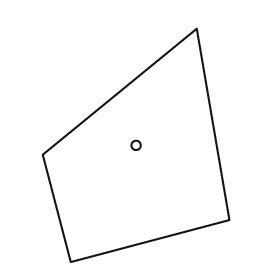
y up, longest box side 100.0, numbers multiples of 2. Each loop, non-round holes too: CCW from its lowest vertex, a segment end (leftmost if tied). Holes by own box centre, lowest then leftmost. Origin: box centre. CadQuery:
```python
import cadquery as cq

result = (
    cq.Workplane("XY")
    .moveTo(-28.0, -50.0)
    .lineTo(40.0, -32.0)
    .lineTo(26.0, 50.0)
    .lineTo(-40.0, -4.0)
    .close()
    .moveTo(0.0, 0.0)
    .circle(2.0)
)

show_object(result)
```